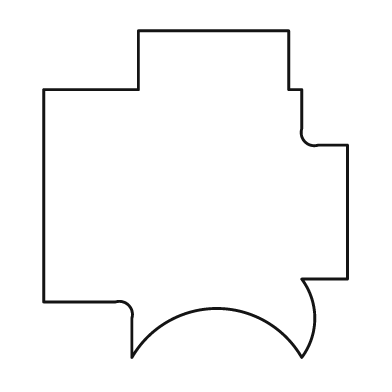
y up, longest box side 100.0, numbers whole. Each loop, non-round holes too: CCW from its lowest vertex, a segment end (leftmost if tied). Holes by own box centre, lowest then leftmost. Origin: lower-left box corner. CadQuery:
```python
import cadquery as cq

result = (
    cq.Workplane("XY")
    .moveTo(27.0, 0.0)
    .threePointArc((53.0, 15.0), (79.0, 0.0))
    .threePointArc((83.0, 12.0), (79.0, 24.0))
    .lineTo(93.0, 24.0)
    .lineTo(93.0, 65.0)
    .lineTo(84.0, 65.0)
    .threePointArc((80.0, 66.0), (79.0, 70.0))
    .lineTo(79.0, 82.0)
    .lineTo(75.0, 82.0)
    .lineTo(75.0, 100.0)
    .lineTo(29.0, 100.0)
    .lineTo(29.0, 82.0)
    .lineTo(0.0, 82.0)
    .lineTo(0.0, 17.0)
    .lineTo(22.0, 17.0)
    .threePointArc((26.0, 16.0), (27.0, 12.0))
    .close()
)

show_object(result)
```